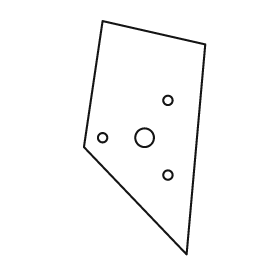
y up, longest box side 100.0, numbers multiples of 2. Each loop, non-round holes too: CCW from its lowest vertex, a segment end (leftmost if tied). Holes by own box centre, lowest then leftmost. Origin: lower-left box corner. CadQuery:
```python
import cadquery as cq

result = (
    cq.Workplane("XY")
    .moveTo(44.0, 0.0)
    .lineTo(52.0, 90.0)
    .lineTo(8.0, 100.0)
    .lineTo(0.0, 46.0)
    .close()
    .moveTo(36.0, 34.0)
    .circle(2.0)
    .moveTo(8.0, 50.0)
    .circle(2.0)
    .moveTo(26.0, 50.0)
    .circle(4.0)
    .moveTo(36.0, 66.0)
    .circle(2.0)
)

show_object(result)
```